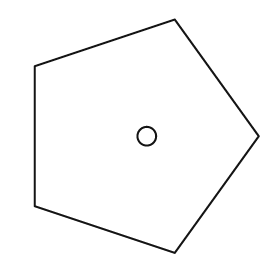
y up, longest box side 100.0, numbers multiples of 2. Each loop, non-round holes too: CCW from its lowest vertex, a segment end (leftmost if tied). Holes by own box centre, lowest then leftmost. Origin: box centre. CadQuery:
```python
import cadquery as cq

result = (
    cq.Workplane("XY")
    .moveTo(12.0, -50.0)
    .lineTo(48.0, 0.0)
    .lineTo(12.0, 50.0)
    .lineTo(-48.0, 30.0)
    .lineTo(-48.0, -30.0)
    .close()
    .moveTo(0.0, 0.0)
    .circle(4.0)
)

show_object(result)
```